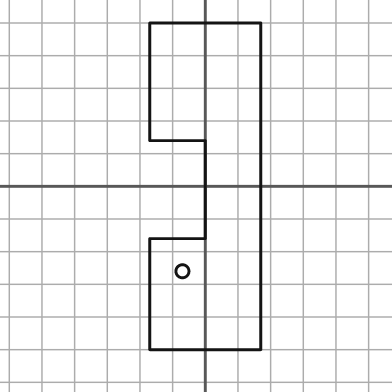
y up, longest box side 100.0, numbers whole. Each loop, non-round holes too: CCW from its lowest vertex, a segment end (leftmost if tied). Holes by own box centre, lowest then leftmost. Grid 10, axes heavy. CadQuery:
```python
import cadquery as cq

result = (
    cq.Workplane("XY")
    .moveTo(-17.0, -50.0)
    .lineTo(17.0, -50.0)
    .lineTo(17.0, 50.0)
    .lineTo(-17.0, 50.0)
    .lineTo(-17.0, 14.0)
    .lineTo(0.0, 14.0)
    .lineTo(0.0, -16.0)
    .lineTo(-17.0, -16.0)
    .close()
    .moveTo(-7.0, -26.0)
    .circle(2.0)
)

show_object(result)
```